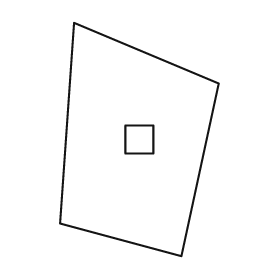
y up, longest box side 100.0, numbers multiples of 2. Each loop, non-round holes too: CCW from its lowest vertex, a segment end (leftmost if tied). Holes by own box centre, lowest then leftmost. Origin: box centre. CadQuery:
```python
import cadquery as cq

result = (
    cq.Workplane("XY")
    .moveTo(18.0, -50.0)
    .lineTo(34.0, 24.0)
    .lineTo(-28.0, 50.0)
    .lineTo(-34.0, -36.0)
    .close()
    .moveTo(-6.0, -6.0)
    .lineTo(6.0, -6.0)
    .lineTo(6.0, 6.0)
    .lineTo(-6.0, 6.0)
    .close()
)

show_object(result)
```